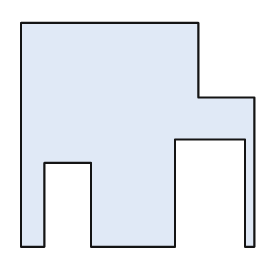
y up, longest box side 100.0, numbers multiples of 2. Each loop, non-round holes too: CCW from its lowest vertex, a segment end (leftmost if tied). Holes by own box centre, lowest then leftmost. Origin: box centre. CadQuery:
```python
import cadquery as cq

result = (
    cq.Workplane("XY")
    .moveTo(-50.0, -48.0)
    .lineTo(-40.0, -48.0)
    .lineTo(-40.0, -12.0)
    .lineTo(-20.0, -12.0)
    .lineTo(-20.0, -48.0)
    .lineTo(16.0, -48.0)
    .lineTo(16.0, -2.0)
    .lineTo(46.0, -2.0)
    .lineTo(46.0, -48.0)
    .lineTo(50.0, -48.0)
    .lineTo(50.0, 16.0)
    .lineTo(26.0, 16.0)
    .lineTo(26.0, 48.0)
    .lineTo(-50.0, 48.0)
    .close()
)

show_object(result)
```